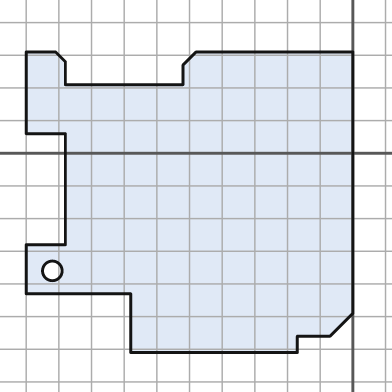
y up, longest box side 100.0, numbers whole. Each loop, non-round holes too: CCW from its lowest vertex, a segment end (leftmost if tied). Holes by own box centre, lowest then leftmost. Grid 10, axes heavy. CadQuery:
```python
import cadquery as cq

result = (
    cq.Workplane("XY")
    .moveTo(-68.0, -61.0)
    .lineTo(-17.0, -61.0)
    .lineTo(-17.0, -56.0)
    .lineTo(-7.0, -56.0)
    .lineTo(0.0, -49.0)
    .lineTo(0.0, 31.0)
    .lineTo(-48.0, 31.0)
    .lineTo(-52.0, 27.0)
    .lineTo(-52.0, 21.0)
    .lineTo(-88.0, 21.0)
    .lineTo(-88.0, 28.0)
    .lineTo(-91.0, 31.0)
    .lineTo(-100.0, 31.0)
    .lineTo(-100.0, 6.0)
    .lineTo(-88.0, 6.0)
    .lineTo(-88.0, -28.0)
    .lineTo(-100.0, -28.0)
    .lineTo(-100.0, -43.0)
    .lineTo(-68.0, -43.0)
    .close()
    .moveTo(-92.0, -36.0)
    .circle(3.0)
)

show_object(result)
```